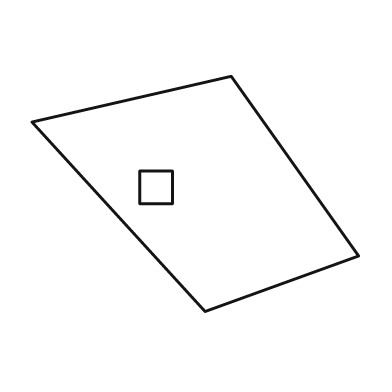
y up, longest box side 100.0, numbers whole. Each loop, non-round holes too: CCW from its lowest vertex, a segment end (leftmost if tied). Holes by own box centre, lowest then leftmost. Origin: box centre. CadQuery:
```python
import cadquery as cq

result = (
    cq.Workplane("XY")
    .moveTo(3.0, -36.0)
    .lineTo(50.0, -19.0)
    .lineTo(11.0, 36.0)
    .lineTo(-50.0, 22.0)
    .close()
    .moveTo(-17.0, -3.0)
    .lineTo(-7.0, -3.0)
    .lineTo(-7.0, 7.0)
    .lineTo(-17.0, 7.0)
    .close()
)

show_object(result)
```